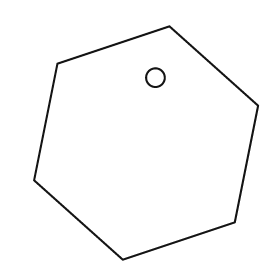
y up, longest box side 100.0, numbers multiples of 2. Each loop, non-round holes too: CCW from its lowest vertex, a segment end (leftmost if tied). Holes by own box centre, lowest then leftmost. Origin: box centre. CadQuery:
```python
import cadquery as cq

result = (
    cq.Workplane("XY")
    .moveTo(-10.0, -50.0)
    .lineTo(38.0, -34.0)
    .lineTo(48.0, 16.0)
    .lineTo(10.0, 50.0)
    .lineTo(-38.0, 34.0)
    .lineTo(-48.0, -16.0)
    .close()
    .moveTo(4.0, 28.0)
    .circle(4.0)
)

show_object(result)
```